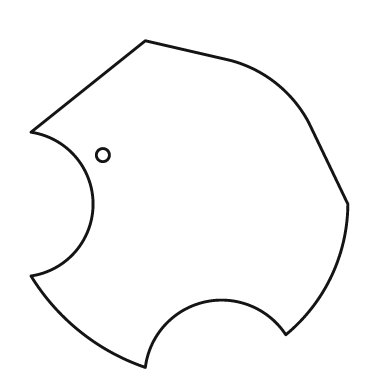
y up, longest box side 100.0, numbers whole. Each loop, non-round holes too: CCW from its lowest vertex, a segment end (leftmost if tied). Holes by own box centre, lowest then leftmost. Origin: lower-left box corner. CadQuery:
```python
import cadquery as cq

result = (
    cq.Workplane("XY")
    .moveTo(35.0, 0.0)
    .threePointArc((53.0, 20.0), (78.0, 10.0))
    .threePointArc((92.0, 28.0), (97.0, 50.0))
    .lineTo(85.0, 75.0)
    .threePointArc((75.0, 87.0), (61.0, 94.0))
    .lineTo(35.0, 100.0)
    .lineTo(0.0, 72.0)
    .threePointArc((19.0, 50.0), (0.0, 28.0))
    .threePointArc((15.0, 11.0), (35.0, 0.0))
    .close()
    .moveTo(22.0, 65.0)
    .circle(2.0)
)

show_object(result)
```